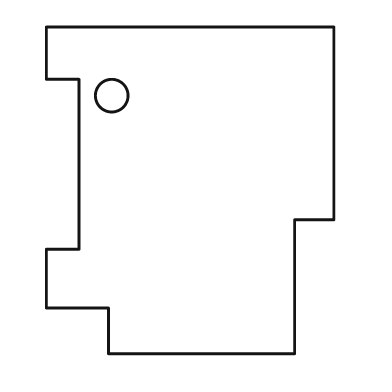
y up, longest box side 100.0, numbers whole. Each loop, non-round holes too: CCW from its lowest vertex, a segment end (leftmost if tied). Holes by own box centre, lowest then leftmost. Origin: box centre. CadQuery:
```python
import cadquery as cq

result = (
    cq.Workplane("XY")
    .moveTo(-25.0, -50.0)
    .lineTo(32.0, -50.0)
    .lineTo(32.0, -9.0)
    .lineTo(44.0, -9.0)
    .lineTo(44.0, 50.0)
    .lineTo(-44.0, 50.0)
    .lineTo(-44.0, 34.0)
    .lineTo(-34.0, 34.0)
    .lineTo(-34.0, -18.0)
    .lineTo(-44.0, -18.0)
    .lineTo(-44.0, -36.0)
    .lineTo(-25.0, -36.0)
    .close()
    .moveTo(-24.0, 29.0)
    .circle(5.0)
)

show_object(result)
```